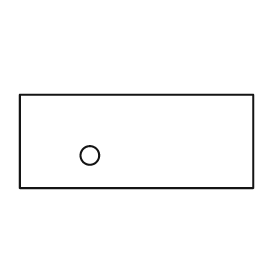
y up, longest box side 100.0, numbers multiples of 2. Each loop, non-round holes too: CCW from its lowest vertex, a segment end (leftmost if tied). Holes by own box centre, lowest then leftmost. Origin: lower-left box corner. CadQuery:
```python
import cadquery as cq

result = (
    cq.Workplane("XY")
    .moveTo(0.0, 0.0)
    .lineTo(100.0, 0.0)
    .lineTo(100.0, 40.0)
    .lineTo(0.0, 40.0)
    .close()
    .moveTo(30.0, 14.0)
    .circle(4.0)
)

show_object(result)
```